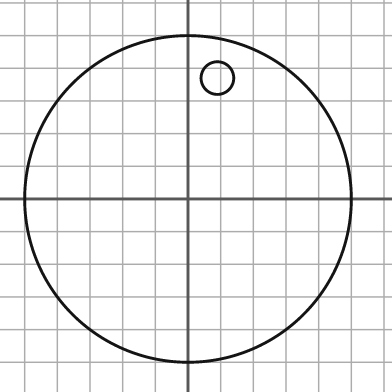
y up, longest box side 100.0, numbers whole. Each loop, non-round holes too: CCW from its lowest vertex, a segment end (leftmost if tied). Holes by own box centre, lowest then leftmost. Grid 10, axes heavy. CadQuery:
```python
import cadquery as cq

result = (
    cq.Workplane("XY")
    .moveTo(0.0, 0.0)
    .circle(50.0)
    .moveTo(9.0, 37.0)
    .circle(5.0)
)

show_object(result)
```